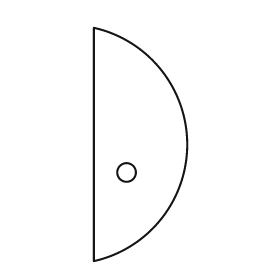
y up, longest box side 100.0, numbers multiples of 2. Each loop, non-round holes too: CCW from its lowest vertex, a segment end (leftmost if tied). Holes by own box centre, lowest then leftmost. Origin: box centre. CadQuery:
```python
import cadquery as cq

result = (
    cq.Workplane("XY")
    .moveTo(-20.0, -50.0)
    .threePointArc((20.0, 0.0), (-20.0, 50.0))
    .close()
    .moveTo(-6.0, -12.0)
    .circle(4.0)
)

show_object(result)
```